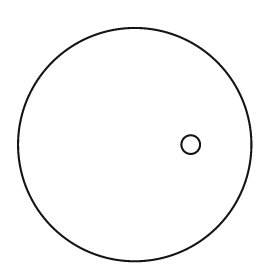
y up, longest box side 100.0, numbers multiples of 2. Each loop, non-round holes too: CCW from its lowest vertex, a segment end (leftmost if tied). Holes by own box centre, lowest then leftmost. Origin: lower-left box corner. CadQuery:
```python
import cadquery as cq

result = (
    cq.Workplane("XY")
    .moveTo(50.0, 50.0)
    .circle(50.0)
    .moveTo(74.0, 50.0)
    .circle(4.0)
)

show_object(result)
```